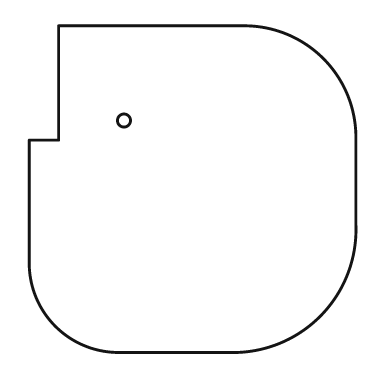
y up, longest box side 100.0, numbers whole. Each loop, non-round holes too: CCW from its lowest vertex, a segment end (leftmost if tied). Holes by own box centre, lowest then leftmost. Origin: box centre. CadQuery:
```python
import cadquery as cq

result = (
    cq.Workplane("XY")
    .moveTo(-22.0, -50.0)
    .lineTo(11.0, -50.0)
    .threePointArc((39.0, -39.0), (50.0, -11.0))
    .lineTo(50.0, 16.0)
    .threePointArc((40.0, 40.0), (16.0, 50.0))
    .lineTo(-41.0, 50.0)
    .lineTo(-41.0, 15.0)
    .lineTo(-50.0, 15.0)
    .lineTo(-50.0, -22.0)
    .threePointArc((-42.0, -42.0), (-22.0, -50.0))
    .close()
    .moveTo(-21.0, 21.0)
    .circle(2.0)
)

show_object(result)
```